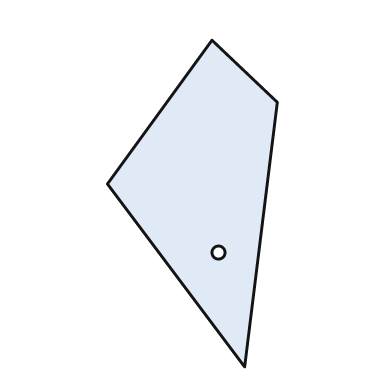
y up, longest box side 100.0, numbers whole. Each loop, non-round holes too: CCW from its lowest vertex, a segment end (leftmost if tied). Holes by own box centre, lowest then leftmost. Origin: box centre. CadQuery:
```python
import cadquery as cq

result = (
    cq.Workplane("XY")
    .moveTo(16.0, -50.0)
    .lineTo(26.0, 31.0)
    .lineTo(6.0, 50.0)
    .lineTo(-26.0, 6.0)
    .close()
    .moveTo(8.0, -15.0)
    .circle(2.0)
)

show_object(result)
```